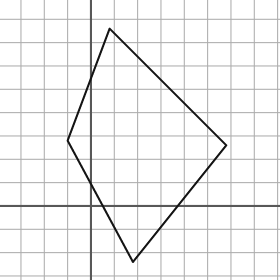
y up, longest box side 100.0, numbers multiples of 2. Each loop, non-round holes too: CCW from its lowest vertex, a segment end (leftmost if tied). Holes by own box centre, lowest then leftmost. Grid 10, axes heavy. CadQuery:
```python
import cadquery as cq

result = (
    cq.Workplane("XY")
    .moveTo(18.0, -24.0)
    .lineTo(58.0, 26.0)
    .lineTo(8.0, 76.0)
    .lineTo(-10.0, 28.0)
    .close()
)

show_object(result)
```